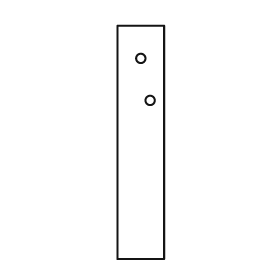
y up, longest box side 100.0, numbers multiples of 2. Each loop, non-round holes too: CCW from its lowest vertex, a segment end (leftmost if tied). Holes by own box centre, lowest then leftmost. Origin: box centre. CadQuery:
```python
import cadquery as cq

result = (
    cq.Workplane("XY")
    .moveTo(-10.0, -50.0)
    .lineTo(10.0, -50.0)
    .lineTo(10.0, 50.0)
    .lineTo(-10.0, 50.0)
    .close()
    .moveTo(4.0, 18.0)
    .circle(2.0)
    .moveTo(0.0, 36.0)
    .circle(2.0)
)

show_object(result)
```